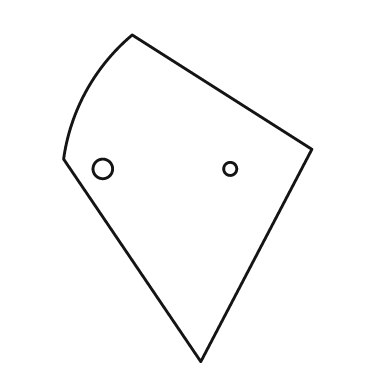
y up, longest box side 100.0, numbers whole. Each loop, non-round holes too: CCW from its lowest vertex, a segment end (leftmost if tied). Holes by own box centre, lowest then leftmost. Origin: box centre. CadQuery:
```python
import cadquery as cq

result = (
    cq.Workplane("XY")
    .moveTo(4.0, -50.0)
    .lineTo(38.0, 15.0)
    .lineTo(-17.0, 50.0)
    .threePointArc((-31.0, 33.0), (-38.0, 12.0))
    .close()
    .moveTo(-26.0, 9.0)
    .circle(3.0)
    .moveTo(13.0, 9.0)
    .circle(2.0)
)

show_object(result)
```